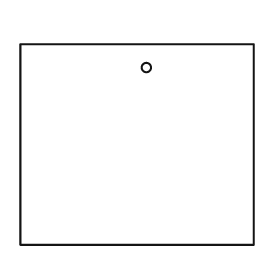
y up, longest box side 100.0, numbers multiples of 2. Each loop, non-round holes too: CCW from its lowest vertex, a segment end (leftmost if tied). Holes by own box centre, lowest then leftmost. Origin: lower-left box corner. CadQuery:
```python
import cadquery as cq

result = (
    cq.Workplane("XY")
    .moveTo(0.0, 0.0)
    .lineTo(100.0, 0.0)
    .lineTo(100.0, 86.0)
    .lineTo(0.0, 86.0)
    .close()
    .moveTo(54.0, 76.0)
    .circle(2.0)
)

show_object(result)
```